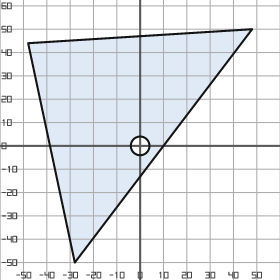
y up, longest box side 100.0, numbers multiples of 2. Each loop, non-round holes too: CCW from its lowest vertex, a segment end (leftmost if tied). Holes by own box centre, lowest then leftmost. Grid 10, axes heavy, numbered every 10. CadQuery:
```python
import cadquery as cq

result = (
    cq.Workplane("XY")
    .moveTo(-28.0, -50.0)
    .lineTo(48.0, 50.0)
    .lineTo(-48.0, 44.0)
    .close()
    .moveTo(0.0, 0.0)
    .circle(4.0)
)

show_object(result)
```